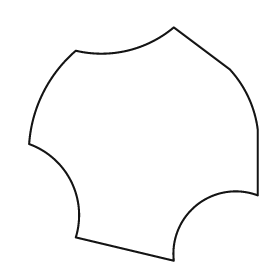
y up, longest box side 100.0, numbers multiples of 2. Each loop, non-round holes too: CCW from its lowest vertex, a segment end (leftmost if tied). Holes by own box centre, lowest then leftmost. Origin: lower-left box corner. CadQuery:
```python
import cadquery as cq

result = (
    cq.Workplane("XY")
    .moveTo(62.0, 0.0)
    .threePointArc((72.0, 24.0), (98.0, 28.0))
    .lineTo(98.0, 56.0)
    .threePointArc((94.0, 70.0), (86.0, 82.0))
    .lineTo(62.0, 100.0)
    .threePointArc((42.0, 90.0), (20.0, 90.0))
    .threePointArc((6.0, 72.0), (0.0, 50.0))
    .threePointArc((18.0, 34.0), (20.0, 10.0))
    .close()
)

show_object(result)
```